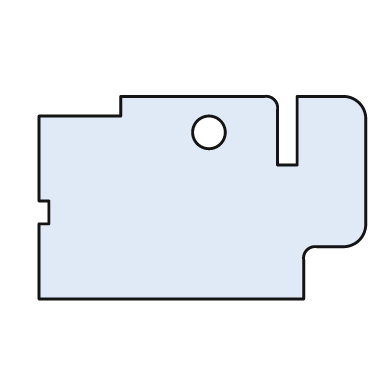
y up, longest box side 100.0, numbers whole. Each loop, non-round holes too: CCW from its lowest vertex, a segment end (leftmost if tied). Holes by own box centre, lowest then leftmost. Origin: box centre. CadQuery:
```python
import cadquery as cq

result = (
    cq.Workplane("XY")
    .moveTo(-50.0, -31.0)
    .lineTo(31.0, -31.0)
    .lineTo(31.0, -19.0)
    .threePointArc((32.0, -16.0), (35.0, -15.0))
    .lineTo(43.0, -15.0)
    .threePointArc((48.0, -13.0), (50.0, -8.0))
    .lineTo(50.0, 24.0)
    .threePointArc((48.0, 29.0), (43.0, 31.0))
    .lineTo(29.0, 31.0)
    .lineTo(29.0, 10.0)
    .lineTo(23.0, 10.0)
    .lineTo(23.0, 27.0)
    .threePointArc((22.0, 30.0), (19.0, 31.0))
    .lineTo(-25.0, 31.0)
    .lineTo(-25.0, 25.0)
    .lineTo(-50.0, 25.0)
    .lineTo(-50.0, -1.0)
    .lineTo(-47.0, -1.0)
    .lineTo(-47.0, -8.0)
    .lineTo(-50.0, -8.0)
    .close()
    .moveTo(2.0, 20.0)
    .circle(5.0)
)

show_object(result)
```